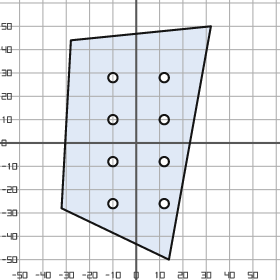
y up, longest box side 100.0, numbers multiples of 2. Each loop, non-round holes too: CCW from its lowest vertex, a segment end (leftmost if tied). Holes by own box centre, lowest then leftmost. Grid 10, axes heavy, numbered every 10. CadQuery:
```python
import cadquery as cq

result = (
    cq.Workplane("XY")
    .moveTo(14.0, -50.0)
    .lineTo(32.0, 50.0)
    .lineTo(-28.0, 44.0)
    .lineTo(-32.0, -28.0)
    .close()
    .moveTo(-10.0, -26.0)
    .circle(2.0)
    .moveTo(12.0, -26.0)
    .circle(2.0)
    .moveTo(-10.0, -8.0)
    .circle(2.0)
    .moveTo(12.0, -8.0)
    .circle(2.0)
    .moveTo(-10.0, 10.0)
    .circle(2.0)
    .moveTo(12.0, 10.0)
    .circle(2.0)
    .moveTo(-10.0, 28.0)
    .circle(2.0)
    .moveTo(12.0, 28.0)
    .circle(2.0)
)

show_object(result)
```